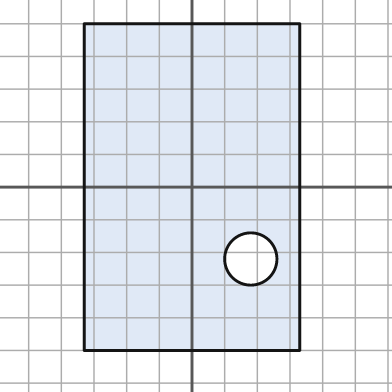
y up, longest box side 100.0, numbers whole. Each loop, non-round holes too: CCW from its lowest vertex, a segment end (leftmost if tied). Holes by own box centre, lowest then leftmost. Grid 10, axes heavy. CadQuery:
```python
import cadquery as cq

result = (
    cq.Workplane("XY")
    .moveTo(-33.0, -50.0)
    .lineTo(33.0, -50.0)
    .lineTo(33.0, 50.0)
    .lineTo(-33.0, 50.0)
    .close()
    .moveTo(18.0, -22.0)
    .circle(8.0)
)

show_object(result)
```